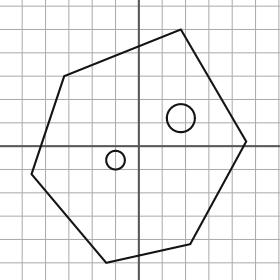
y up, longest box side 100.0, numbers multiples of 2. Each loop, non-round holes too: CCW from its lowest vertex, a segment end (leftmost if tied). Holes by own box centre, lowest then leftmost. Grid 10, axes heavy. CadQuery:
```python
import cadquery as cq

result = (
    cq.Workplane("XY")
    .moveTo(-14.0, -50.0)
    .lineTo(22.0, -42.0)
    .lineTo(46.0, 2.0)
    .lineTo(18.0, 50.0)
    .lineTo(-32.0, 30.0)
    .lineTo(-46.0, -12.0)
    .close()
    .moveTo(-10.0, -6.0)
    .circle(4.0)
    .moveTo(18.0, 12.0)
    .circle(6.0)
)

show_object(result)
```